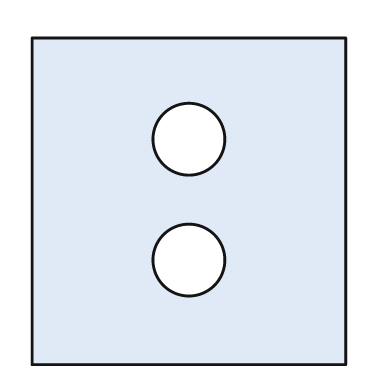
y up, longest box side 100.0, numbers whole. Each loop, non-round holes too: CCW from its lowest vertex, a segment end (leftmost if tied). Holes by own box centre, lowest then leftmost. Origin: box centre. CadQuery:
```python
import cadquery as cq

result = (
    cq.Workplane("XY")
    .moveTo(-48.0, -50.0)
    .lineTo(48.0, -50.0)
    .lineTo(48.0, 50.0)
    .lineTo(-48.0, 50.0)
    .close()
    .moveTo(0.0, -18.0)
    .circle(11.0)
    .moveTo(0.0, 19.0)
    .circle(11.0)
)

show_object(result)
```